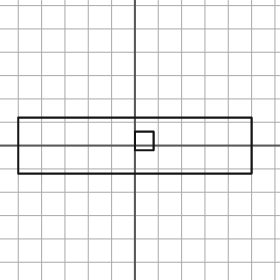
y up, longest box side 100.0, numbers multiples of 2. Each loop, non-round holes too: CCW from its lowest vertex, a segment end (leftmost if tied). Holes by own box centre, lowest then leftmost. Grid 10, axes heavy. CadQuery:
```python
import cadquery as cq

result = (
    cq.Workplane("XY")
    .moveTo(-50.0, -12.0)
    .lineTo(50.0, -12.0)
    .lineTo(50.0, 12.0)
    .lineTo(-50.0, 12.0)
    .close()
    .moveTo(0.0, -2.0)
    .lineTo(8.0, -2.0)
    .lineTo(8.0, 6.0)
    .lineTo(0.0, 6.0)
    .close()
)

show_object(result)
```